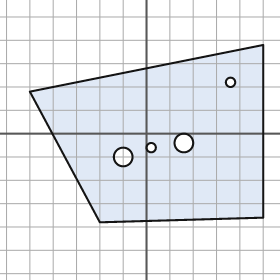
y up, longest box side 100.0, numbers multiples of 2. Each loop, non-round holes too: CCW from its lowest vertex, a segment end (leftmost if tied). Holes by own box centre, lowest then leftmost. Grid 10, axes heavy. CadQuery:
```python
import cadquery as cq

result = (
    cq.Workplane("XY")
    .moveTo(-20.0, -38.0)
    .lineTo(50.0, -36.0)
    .lineTo(50.0, 38.0)
    .lineTo(-50.0, 18.0)
    .close()
    .moveTo(-10.0, -10.0)
    .circle(4.0)
    .moveTo(2.0, -6.0)
    .circle(2.0)
    .moveTo(16.0, -4.0)
    .circle(4.0)
    .moveTo(36.0, 22.0)
    .circle(2.0)
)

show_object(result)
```